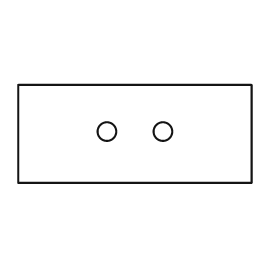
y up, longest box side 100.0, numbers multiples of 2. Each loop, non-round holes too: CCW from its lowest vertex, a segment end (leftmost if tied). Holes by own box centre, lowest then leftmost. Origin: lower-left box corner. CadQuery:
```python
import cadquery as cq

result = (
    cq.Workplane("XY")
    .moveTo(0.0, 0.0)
    .lineTo(100.0, 0.0)
    .lineTo(100.0, 42.0)
    .lineTo(0.0, 42.0)
    .close()
    .moveTo(38.0, 22.0)
    .circle(4.0)
    .moveTo(62.0, 22.0)
    .circle(4.0)
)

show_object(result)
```